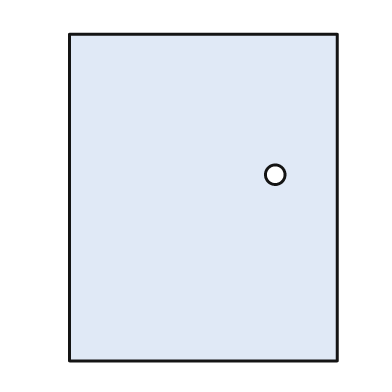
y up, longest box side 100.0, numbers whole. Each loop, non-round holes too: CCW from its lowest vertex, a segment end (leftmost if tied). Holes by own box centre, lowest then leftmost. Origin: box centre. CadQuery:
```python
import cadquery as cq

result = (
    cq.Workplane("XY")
    .moveTo(-41.0, -50.0)
    .lineTo(41.0, -50.0)
    .lineTo(41.0, 50.0)
    .lineTo(-41.0, 50.0)
    .close()
    .moveTo(22.0, 7.0)
    .circle(3.0)
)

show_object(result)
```